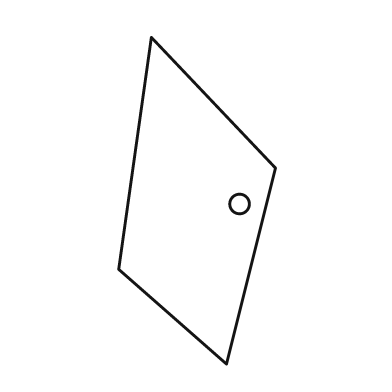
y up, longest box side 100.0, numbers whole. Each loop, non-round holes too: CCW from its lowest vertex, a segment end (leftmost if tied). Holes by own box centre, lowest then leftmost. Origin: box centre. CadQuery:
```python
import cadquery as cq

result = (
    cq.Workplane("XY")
    .moveTo(9.0, -50.0)
    .lineTo(24.0, 10.0)
    .lineTo(-14.0, 50.0)
    .lineTo(-24.0, -21.0)
    .close()
    .moveTo(13.0, -1.0)
    .circle(3.0)
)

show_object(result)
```